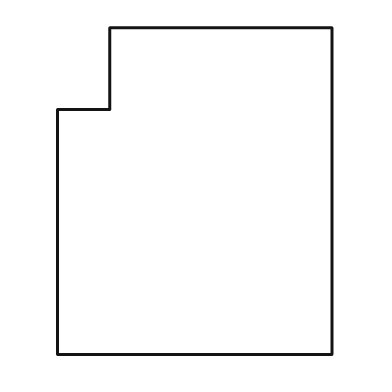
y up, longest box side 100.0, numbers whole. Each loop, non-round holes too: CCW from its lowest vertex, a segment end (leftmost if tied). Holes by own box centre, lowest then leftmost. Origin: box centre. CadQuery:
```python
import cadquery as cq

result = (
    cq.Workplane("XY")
    .moveTo(-42.0, -50.0)
    .lineTo(42.0, -50.0)
    .lineTo(42.0, 50.0)
    .lineTo(-26.0, 50.0)
    .lineTo(-26.0, 25.0)
    .lineTo(-42.0, 25.0)
    .close()
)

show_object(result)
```